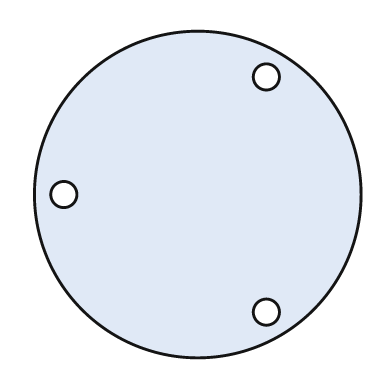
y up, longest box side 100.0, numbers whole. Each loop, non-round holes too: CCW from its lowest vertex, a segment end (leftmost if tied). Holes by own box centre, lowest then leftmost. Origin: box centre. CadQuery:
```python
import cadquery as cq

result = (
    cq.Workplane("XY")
    .moveTo(0.0, 0.0)
    .circle(50.0)
    .moveTo(21.0, -36.0)
    .circle(4.0)
    .moveTo(-41.0, 0.0)
    .circle(4.0)
    .moveTo(21.0, 36.0)
    .circle(4.0)
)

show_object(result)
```